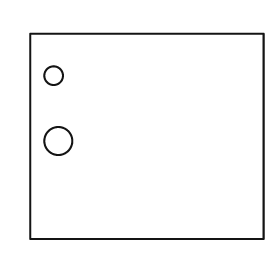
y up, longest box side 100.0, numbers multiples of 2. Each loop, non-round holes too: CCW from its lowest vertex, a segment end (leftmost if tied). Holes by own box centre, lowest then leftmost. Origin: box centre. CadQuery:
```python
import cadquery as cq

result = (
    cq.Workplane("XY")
    .moveTo(-50.0, -44.0)
    .lineTo(50.0, -44.0)
    .lineTo(50.0, 44.0)
    .lineTo(-50.0, 44.0)
    .close()
    .moveTo(-38.0, -2.0)
    .circle(6.0)
    .moveTo(-40.0, 26.0)
    .circle(4.0)
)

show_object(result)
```